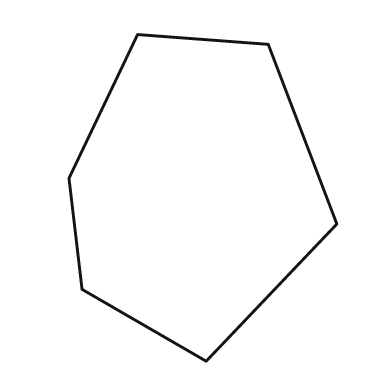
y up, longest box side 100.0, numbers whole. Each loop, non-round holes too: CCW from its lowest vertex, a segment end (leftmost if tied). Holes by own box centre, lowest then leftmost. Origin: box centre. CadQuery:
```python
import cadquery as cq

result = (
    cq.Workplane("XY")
    .moveTo(1.0, -50.0)
    .lineTo(41.0, -8.0)
    .lineTo(20.0, 47.0)
    .lineTo(-20.0, 50.0)
    .lineTo(-41.0, 6.0)
    .lineTo(-37.0, -28.0)
    .close()
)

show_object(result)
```